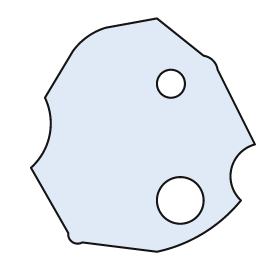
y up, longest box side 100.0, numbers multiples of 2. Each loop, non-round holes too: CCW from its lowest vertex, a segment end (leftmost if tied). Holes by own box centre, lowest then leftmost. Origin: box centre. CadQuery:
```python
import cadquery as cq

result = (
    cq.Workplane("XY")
    .moveTo(6.0, -50.0)
    .threePointArc((26.0, -42.0), (42.0, -28.0))
    .threePointArc((38.0, -14.0), (48.0, -4.0))
    .lineTo(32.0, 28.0)
    .threePointArc((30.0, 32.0), (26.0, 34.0))
    .lineTo(6.0, 50.0)
    .lineTo(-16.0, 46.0)
    .threePointArc((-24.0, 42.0), (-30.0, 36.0))
    .lineTo(-42.0, 16.0)
    .threePointArc((-40.0, 0.0), (-48.0, -14.0))
    .lineTo(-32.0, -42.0)
    .threePointArc((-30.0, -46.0), (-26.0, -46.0))
    .close()
    .moveTo(16.0, -28.0)
    .circle(10.0)
    .moveTo(12.0, 22.0)
    .circle(6.0)
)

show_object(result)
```